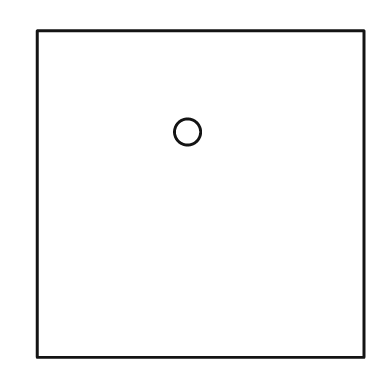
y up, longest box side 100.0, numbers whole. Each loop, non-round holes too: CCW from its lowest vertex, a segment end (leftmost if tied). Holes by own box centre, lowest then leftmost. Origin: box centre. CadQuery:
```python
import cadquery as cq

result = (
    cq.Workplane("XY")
    .moveTo(-50.0, -50.0)
    .lineTo(50.0, -50.0)
    .lineTo(50.0, 50.0)
    .lineTo(-50.0, 50.0)
    .close()
    .moveTo(-4.0, 19.0)
    .circle(4.0)
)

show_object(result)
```